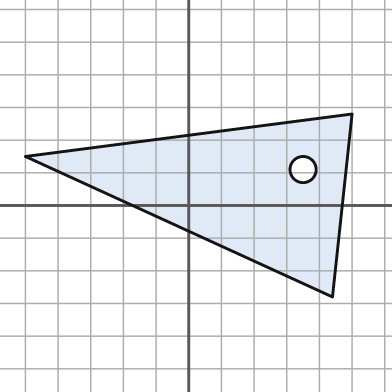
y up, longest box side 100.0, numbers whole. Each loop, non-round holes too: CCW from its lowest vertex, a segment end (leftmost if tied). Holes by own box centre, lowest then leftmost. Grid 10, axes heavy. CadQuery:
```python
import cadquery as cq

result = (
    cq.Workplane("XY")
    .moveTo(44.0, -28.0)
    .lineTo(50.0, 28.0)
    .lineTo(-50.0, 15.0)
    .close()
    .moveTo(35.0, 11.0)
    .circle(4.0)
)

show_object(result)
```